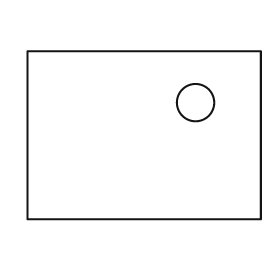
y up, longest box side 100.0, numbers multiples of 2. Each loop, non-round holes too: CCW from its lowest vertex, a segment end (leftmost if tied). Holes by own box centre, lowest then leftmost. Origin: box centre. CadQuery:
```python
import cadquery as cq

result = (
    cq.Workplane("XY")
    .moveTo(-50.0, -36.0)
    .lineTo(50.0, -36.0)
    .lineTo(50.0, 36.0)
    .lineTo(-50.0, 36.0)
    .close()
    .moveTo(22.0, 14.0)
    .circle(8.0)
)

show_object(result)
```